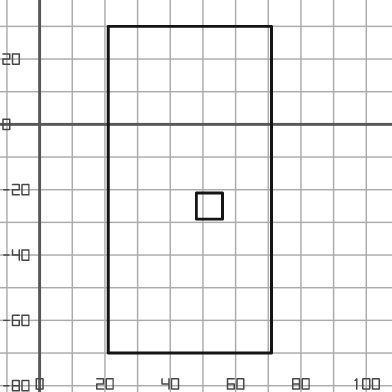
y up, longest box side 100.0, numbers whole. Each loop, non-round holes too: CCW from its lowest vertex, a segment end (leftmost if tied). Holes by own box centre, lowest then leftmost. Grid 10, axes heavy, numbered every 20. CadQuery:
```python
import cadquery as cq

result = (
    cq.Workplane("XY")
    .moveTo(21.0, -70.0)
    .lineTo(71.0, -70.0)
    .lineTo(71.0, 30.0)
    .lineTo(21.0, 30.0)
    .close()
    .moveTo(48.0, -29.0)
    .lineTo(56.0, -29.0)
    .lineTo(56.0, -21.0)
    .lineTo(48.0, -21.0)
    .close()
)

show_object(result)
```